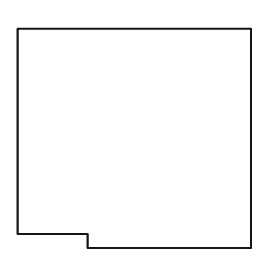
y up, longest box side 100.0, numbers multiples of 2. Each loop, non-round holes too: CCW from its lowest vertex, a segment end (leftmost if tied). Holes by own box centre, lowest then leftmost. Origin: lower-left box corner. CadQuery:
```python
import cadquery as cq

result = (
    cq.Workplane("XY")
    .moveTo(30.0, 0.0)
    .lineTo(100.0, 0.0)
    .lineTo(100.0, 94.0)
    .lineTo(0.0, 94.0)
    .lineTo(0.0, 6.0)
    .lineTo(30.0, 6.0)
    .close()
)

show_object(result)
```